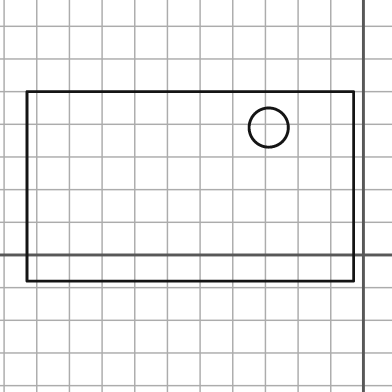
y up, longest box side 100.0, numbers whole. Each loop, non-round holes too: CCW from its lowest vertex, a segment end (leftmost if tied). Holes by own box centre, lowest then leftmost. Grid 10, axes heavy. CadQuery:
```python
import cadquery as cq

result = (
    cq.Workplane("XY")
    .moveTo(-103.0, -8.0)
    .lineTo(-3.0, -8.0)
    .lineTo(-3.0, 50.0)
    .lineTo(-103.0, 50.0)
    .close()
    .moveTo(-29.0, 39.0)
    .circle(6.0)
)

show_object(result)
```